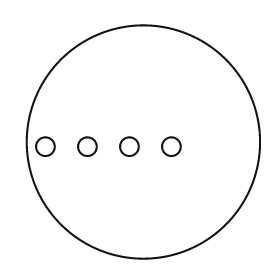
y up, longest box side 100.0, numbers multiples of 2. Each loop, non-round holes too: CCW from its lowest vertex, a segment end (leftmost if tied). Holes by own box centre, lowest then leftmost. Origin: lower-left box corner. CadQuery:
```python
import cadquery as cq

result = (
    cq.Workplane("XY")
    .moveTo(50.0, 50.0)
    .circle(50.0)
    .moveTo(8.0, 48.0)
    .circle(4.0)
    .moveTo(26.0, 48.0)
    .circle(4.0)
    .moveTo(44.0, 48.0)
    .circle(4.0)
    .moveTo(62.0, 48.0)
    .circle(4.0)
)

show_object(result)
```